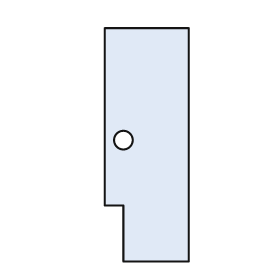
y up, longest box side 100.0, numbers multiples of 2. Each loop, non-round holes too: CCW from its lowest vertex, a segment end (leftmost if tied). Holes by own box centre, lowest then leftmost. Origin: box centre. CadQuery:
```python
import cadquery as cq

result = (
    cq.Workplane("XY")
    .moveTo(-10.0, -50.0)
    .lineTo(18.0, -50.0)
    .lineTo(18.0, 50.0)
    .lineTo(-18.0, 50.0)
    .lineTo(-18.0, -26.0)
    .lineTo(-10.0, -26.0)
    .close()
    .moveTo(-10.0, 2.0)
    .circle(4.0)
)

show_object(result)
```